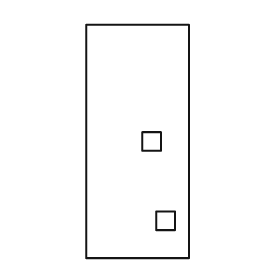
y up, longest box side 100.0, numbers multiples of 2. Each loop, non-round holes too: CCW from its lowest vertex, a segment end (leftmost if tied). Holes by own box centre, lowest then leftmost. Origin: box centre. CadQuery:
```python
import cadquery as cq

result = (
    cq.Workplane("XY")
    .moveTo(-22.0, -50.0)
    .lineTo(22.0, -50.0)
    .lineTo(22.0, 50.0)
    .lineTo(-22.0, 50.0)
    .close()
    .moveTo(8.0, -38.0)
    .lineTo(16.0, -38.0)
    .lineTo(16.0, -30.0)
    .lineTo(8.0, -30.0)
    .close()
    .moveTo(2.0, -4.0)
    .lineTo(10.0, -4.0)
    .lineTo(10.0, 4.0)
    .lineTo(2.0, 4.0)
    .close()
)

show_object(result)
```